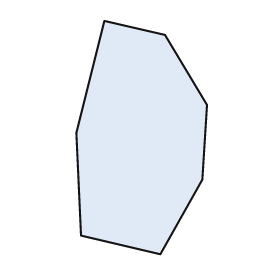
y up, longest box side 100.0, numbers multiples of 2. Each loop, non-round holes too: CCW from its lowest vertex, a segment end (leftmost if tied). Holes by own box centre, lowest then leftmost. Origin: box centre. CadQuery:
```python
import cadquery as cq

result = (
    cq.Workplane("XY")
    .moveTo(8.0, -50.0)
    .lineTo(26.0, -18.0)
    .lineTo(28.0, 14.0)
    .lineTo(10.0, 44.0)
    .lineTo(-16.0, 50.0)
    .lineTo(-28.0, 2.0)
    .lineTo(-26.0, -42.0)
    .close()
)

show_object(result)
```